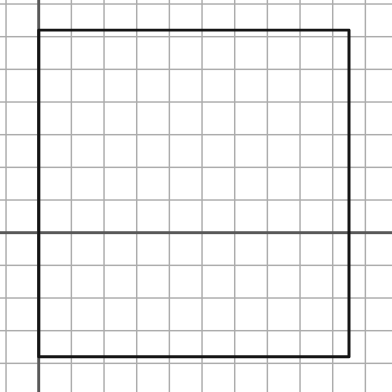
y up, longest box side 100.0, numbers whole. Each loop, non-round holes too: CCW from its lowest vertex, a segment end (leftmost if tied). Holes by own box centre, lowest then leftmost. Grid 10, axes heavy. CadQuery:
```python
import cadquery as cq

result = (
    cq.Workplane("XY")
    .moveTo(0.0, -38.0)
    .lineTo(95.0, -38.0)
    .lineTo(95.0, 62.0)
    .lineTo(0.0, 62.0)
    .close()
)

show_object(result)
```